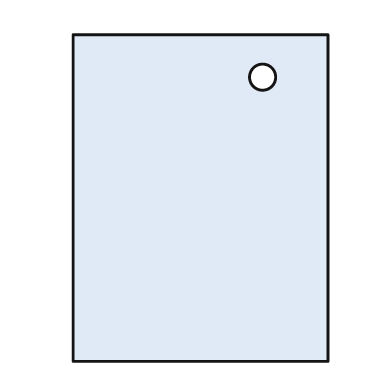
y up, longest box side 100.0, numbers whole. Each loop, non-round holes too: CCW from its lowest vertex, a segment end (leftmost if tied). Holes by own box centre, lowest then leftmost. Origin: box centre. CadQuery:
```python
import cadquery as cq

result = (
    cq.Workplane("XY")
    .moveTo(-39.0, -50.0)
    .lineTo(39.0, -50.0)
    .lineTo(39.0, 50.0)
    .lineTo(-39.0, 50.0)
    .close()
    .moveTo(19.0, 37.0)
    .circle(4.0)
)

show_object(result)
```